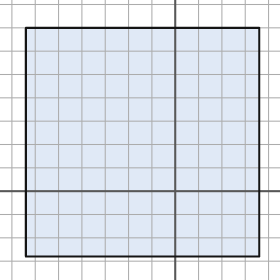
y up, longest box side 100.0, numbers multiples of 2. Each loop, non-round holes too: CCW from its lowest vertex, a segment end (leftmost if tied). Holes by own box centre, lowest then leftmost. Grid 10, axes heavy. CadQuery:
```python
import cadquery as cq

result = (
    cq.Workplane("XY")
    .moveTo(-64.0, -28.0)
    .lineTo(36.0, -28.0)
    .lineTo(36.0, 70.0)
    .lineTo(-64.0, 70.0)
    .close()
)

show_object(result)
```